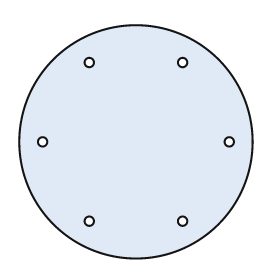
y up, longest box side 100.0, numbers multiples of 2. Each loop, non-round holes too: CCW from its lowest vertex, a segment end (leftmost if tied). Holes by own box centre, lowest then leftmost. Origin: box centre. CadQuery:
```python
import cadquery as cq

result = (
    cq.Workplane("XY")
    .moveTo(0.0, 0.0)
    .circle(50.0)
    .moveTo(-20.0, -34.0)
    .circle(2.0)
    .moveTo(20.0, -34.0)
    .circle(2.0)
    .moveTo(-40.0, 0.0)
    .circle(2.0)
    .moveTo(40.0, 0.0)
    .circle(2.0)
    .moveTo(-20.0, 34.0)
    .circle(2.0)
    .moveTo(20.0, 34.0)
    .circle(2.0)
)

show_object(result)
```